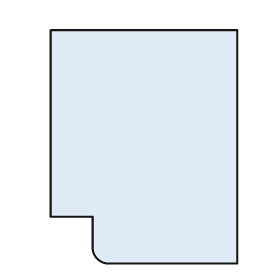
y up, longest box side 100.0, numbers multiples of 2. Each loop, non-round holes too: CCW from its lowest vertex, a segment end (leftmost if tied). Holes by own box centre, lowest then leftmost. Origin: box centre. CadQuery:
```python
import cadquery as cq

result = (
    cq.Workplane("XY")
    .moveTo(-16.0, -50.0)
    .lineTo(40.0, -50.0)
    .lineTo(40.0, 50.0)
    .lineTo(-40.0, 50.0)
    .lineTo(-40.0, -30.0)
    .lineTo(-22.0, -30.0)
    .lineTo(-22.0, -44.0)
    .threePointArc((-20.0, -48.0), (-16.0, -50.0))
    .close()
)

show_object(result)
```